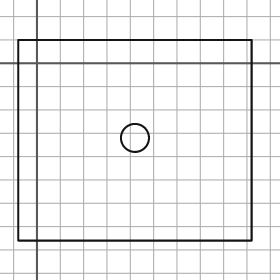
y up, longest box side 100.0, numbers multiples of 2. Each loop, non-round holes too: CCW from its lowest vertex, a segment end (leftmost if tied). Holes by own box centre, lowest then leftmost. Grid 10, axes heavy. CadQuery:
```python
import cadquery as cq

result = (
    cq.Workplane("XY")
    .moveTo(-8.0, -76.0)
    .lineTo(92.0, -76.0)
    .lineTo(92.0, 10.0)
    .lineTo(-8.0, 10.0)
    .close()
    .moveTo(42.0, -32.0)
    .circle(6.0)
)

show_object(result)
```